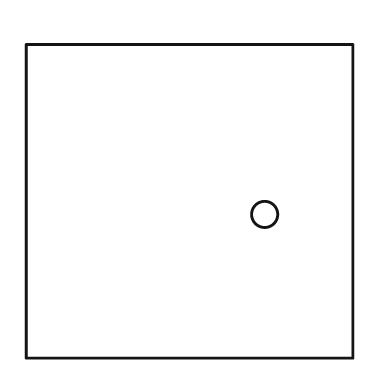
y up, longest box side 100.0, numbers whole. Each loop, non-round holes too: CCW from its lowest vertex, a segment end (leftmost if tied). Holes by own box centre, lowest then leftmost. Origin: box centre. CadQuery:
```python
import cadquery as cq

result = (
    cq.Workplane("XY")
    .moveTo(-50.0, -48.0)
    .lineTo(50.0, -48.0)
    .lineTo(50.0, 48.0)
    .lineTo(-50.0, 48.0)
    .close()
    .moveTo(23.0, -4.0)
    .circle(4.0)
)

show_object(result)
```